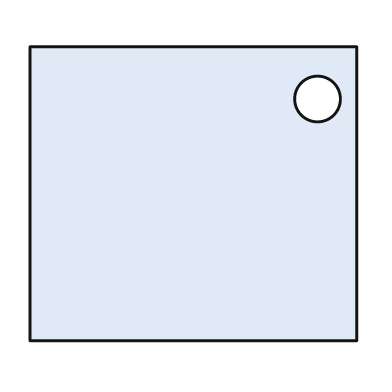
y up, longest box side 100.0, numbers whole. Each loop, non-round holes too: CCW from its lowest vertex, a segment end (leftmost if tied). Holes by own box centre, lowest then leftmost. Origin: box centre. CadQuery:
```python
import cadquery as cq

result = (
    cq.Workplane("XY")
    .moveTo(-50.0, -45.0)
    .lineTo(50.0, -45.0)
    .lineTo(50.0, 45.0)
    .lineTo(-50.0, 45.0)
    .close()
    .moveTo(38.0, 29.0)
    .circle(7.0)
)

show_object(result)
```